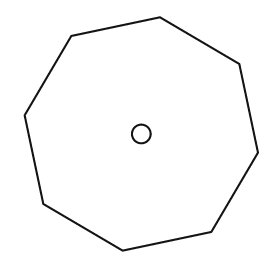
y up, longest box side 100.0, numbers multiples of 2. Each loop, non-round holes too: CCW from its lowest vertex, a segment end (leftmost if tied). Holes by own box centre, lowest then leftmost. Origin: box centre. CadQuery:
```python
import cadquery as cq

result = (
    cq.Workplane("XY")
    .moveTo(-8.0, -50.0)
    .lineTo(30.0, -42.0)
    .lineTo(50.0, -8.0)
    .lineTo(42.0, 30.0)
    .lineTo(8.0, 50.0)
    .lineTo(-30.0, 42.0)
    .lineTo(-50.0, 8.0)
    .lineTo(-42.0, -30.0)
    .close()
    .moveTo(0.0, 0.0)
    .circle(4.0)
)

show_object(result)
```